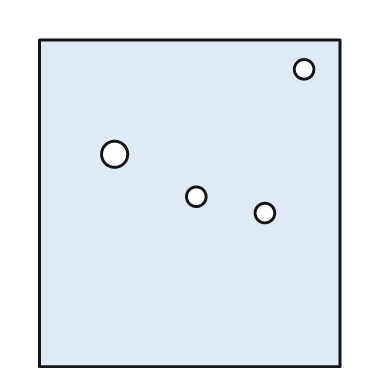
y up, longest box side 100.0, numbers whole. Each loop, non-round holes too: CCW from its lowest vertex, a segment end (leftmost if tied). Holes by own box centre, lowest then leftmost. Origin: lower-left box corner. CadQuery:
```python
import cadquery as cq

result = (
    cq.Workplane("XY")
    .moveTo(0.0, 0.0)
    .lineTo(92.0, 0.0)
    .lineTo(92.0, 100.0)
    .lineTo(0.0, 100.0)
    .close()
    .moveTo(69.0, 47.0)
    .circle(3.0)
    .moveTo(48.0, 52.0)
    .circle(3.0)
    .moveTo(23.0, 65.0)
    .circle(4.0)
    .moveTo(81.0, 91.0)
    .circle(3.0)
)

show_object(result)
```